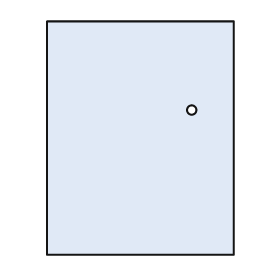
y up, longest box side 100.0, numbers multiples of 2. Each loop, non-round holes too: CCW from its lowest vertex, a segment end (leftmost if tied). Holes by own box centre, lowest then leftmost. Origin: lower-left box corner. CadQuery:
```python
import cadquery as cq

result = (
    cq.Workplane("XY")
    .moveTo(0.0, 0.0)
    .lineTo(80.0, 0.0)
    .lineTo(80.0, 100.0)
    .lineTo(0.0, 100.0)
    .close()
    .moveTo(62.0, 62.0)
    .circle(2.0)
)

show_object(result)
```